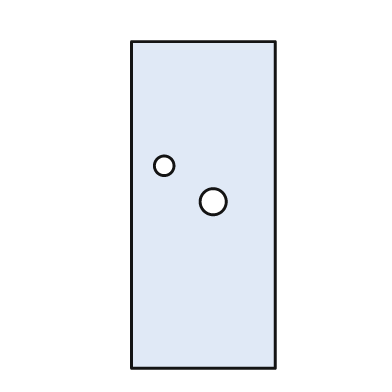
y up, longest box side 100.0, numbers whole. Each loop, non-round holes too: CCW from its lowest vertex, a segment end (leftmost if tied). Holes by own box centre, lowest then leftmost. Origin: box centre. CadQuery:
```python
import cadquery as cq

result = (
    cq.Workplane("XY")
    .moveTo(-22.0, -50.0)
    .lineTo(22.0, -50.0)
    .lineTo(22.0, 50.0)
    .lineTo(-22.0, 50.0)
    .close()
    .moveTo(3.0, 1.0)
    .circle(4.0)
    .moveTo(-12.0, 12.0)
    .circle(3.0)
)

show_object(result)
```